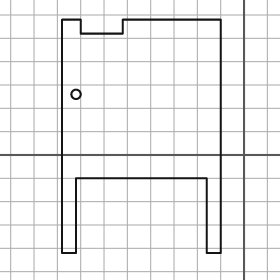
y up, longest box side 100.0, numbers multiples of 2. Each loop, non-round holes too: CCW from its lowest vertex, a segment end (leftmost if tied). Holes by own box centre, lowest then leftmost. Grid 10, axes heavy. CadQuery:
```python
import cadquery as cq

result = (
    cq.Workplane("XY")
    .moveTo(-78.0, -42.0)
    .lineTo(-72.0, -42.0)
    .lineTo(-72.0, -10.0)
    .lineTo(-16.0, -10.0)
    .lineTo(-16.0, -42.0)
    .lineTo(-10.0, -42.0)
    .lineTo(-10.0, 58.0)
    .lineTo(-52.0, 58.0)
    .lineTo(-52.0, 52.0)
    .lineTo(-70.0, 52.0)
    .lineTo(-70.0, 58.0)
    .lineTo(-78.0, 58.0)
    .close()
    .moveTo(-72.0, 26.0)
    .circle(2.0)
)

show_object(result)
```